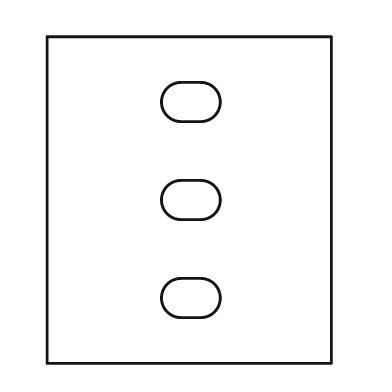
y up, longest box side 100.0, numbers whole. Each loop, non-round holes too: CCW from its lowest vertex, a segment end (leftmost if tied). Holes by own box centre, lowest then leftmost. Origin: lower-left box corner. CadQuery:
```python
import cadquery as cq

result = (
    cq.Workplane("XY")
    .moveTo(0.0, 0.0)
    .lineTo(87.0, 0.0)
    .lineTo(87.0, 100.0)
    .lineTo(0.0, 100.0)
    .close()
    .moveTo(41.0, 14.0)
    .lineTo(47.0, 14.0)
    .threePointArc((53.0, 20.0), (47.0, 26.0))
    .lineTo(41.0, 26.0)
    .threePointArc((35.0, 20.0), (41.0, 14.0))
    .close()
    .moveTo(41.0, 44.0)
    .lineTo(47.0, 44.0)
    .threePointArc((53.0, 50.0), (47.0, 56.0))
    .lineTo(41.0, 56.0)
    .threePointArc((35.0, 50.0), (41.0, 44.0))
    .close()
    .moveTo(41.0, 74.0)
    .lineTo(47.0, 74.0)
    .threePointArc((53.0, 80.0), (47.0, 86.0))
    .lineTo(41.0, 86.0)
    .threePointArc((35.0, 80.0), (41.0, 74.0))
    .close()
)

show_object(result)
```